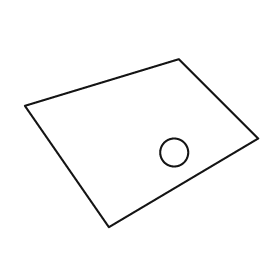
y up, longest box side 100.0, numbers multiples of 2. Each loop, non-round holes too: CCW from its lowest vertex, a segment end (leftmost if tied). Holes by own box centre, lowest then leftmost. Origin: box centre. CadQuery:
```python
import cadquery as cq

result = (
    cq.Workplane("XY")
    .moveTo(-14.0, -36.0)
    .lineTo(50.0, 2.0)
    .lineTo(16.0, 36.0)
    .lineTo(-50.0, 16.0)
    .close()
    .moveTo(14.0, -4.0)
    .circle(6.0)
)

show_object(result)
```